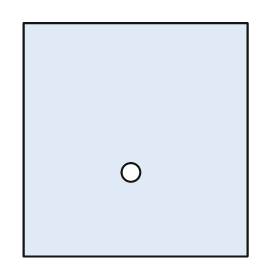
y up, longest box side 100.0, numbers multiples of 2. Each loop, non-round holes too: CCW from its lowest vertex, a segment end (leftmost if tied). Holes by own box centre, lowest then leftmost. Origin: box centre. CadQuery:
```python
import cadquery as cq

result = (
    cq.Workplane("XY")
    .moveTo(-48.0, -50.0)
    .lineTo(48.0, -50.0)
    .lineTo(48.0, 50.0)
    .lineTo(-48.0, 50.0)
    .close()
    .moveTo(-2.0, -14.0)
    .circle(4.0)
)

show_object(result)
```